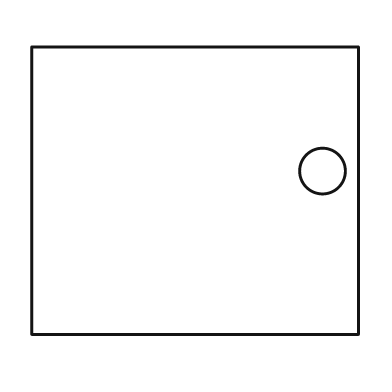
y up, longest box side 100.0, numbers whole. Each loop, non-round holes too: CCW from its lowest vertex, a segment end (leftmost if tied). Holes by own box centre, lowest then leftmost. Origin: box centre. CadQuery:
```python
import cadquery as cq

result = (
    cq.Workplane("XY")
    .moveTo(-50.0, -44.0)
    .lineTo(50.0, -44.0)
    .lineTo(50.0, 44.0)
    .lineTo(-50.0, 44.0)
    .close()
    .moveTo(39.0, 6.0)
    .circle(7.0)
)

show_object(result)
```